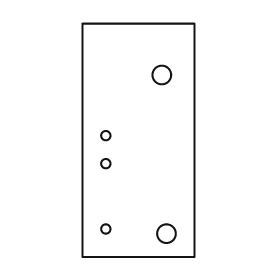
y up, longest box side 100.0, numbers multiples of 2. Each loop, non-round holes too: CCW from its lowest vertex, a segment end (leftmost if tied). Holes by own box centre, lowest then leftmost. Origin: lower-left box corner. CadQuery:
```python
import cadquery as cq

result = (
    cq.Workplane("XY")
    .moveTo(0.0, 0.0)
    .lineTo(48.0, 0.0)
    .lineTo(48.0, 100.0)
    .lineTo(0.0, 100.0)
    .close()
    .moveTo(36.0, 10.0)
    .circle(4.0)
    .moveTo(10.0, 12.0)
    .circle(2.0)
    .moveTo(10.0, 40.0)
    .circle(2.0)
    .moveTo(10.0, 52.0)
    .circle(2.0)
    .moveTo(34.0, 78.0)
    .circle(4.0)
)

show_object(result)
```